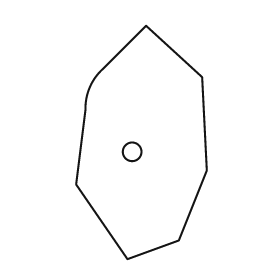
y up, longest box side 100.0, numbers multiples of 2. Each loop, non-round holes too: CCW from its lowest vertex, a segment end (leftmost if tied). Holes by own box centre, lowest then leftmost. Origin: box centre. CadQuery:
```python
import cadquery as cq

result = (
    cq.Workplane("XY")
    .moveTo(-6.0, -50.0)
    .lineTo(16.0, -42.0)
    .lineTo(28.0, -12.0)
    .lineTo(26.0, 28.0)
    .lineTo(2.0, 50.0)
    .lineTo(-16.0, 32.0)
    .threePointArc((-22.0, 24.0), (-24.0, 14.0))
    .lineTo(-28.0, -18.0)
    .close()
    .moveTo(-4.0, -4.0)
    .circle(4.0)
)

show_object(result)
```